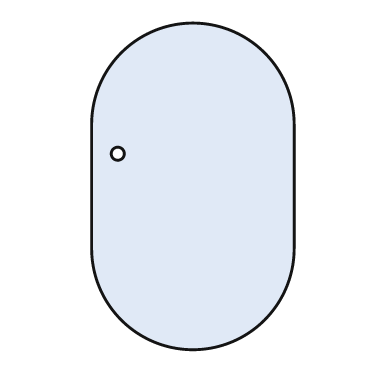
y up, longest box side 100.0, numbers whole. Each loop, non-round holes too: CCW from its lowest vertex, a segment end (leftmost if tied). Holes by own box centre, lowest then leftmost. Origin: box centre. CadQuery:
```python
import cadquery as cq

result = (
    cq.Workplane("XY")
    .moveTo(-31.0, -19.0)
    .threePointArc((0.0, -50.0), (31.0, -19.0))
    .lineTo(31.0, 19.0)
    .threePointArc((0.0, 50.0), (-31.0, 19.0))
    .close()
    .moveTo(-23.0, 10.0)
    .circle(2.0)
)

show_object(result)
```